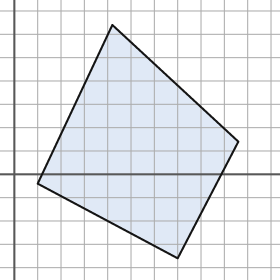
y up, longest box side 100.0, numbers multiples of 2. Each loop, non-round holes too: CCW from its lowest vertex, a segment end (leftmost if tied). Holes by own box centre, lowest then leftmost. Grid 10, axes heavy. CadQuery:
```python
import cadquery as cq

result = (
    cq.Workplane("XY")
    .moveTo(70.0, -36.0)
    .lineTo(96.0, 14.0)
    .lineTo(42.0, 64.0)
    .lineTo(10.0, -4.0)
    .close()
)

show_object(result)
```